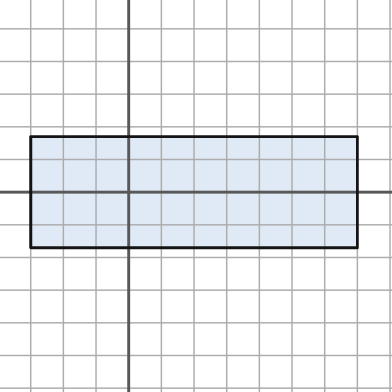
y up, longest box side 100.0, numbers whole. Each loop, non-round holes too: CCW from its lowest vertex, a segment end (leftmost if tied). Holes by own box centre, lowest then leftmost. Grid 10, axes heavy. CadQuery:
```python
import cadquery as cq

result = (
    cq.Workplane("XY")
    .moveTo(-30.0, -17.0)
    .lineTo(70.0, -17.0)
    .lineTo(70.0, 17.0)
    .lineTo(-30.0, 17.0)
    .close()
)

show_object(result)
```